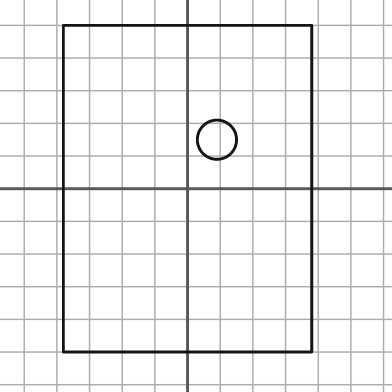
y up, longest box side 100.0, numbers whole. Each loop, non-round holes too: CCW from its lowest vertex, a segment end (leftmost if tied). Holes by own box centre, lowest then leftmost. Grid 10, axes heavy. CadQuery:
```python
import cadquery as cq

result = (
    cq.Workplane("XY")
    .moveTo(-38.0, -50.0)
    .lineTo(38.0, -50.0)
    .lineTo(38.0, 50.0)
    .lineTo(-38.0, 50.0)
    .close()
    .moveTo(9.0, 15.0)
    .circle(6.0)
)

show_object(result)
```